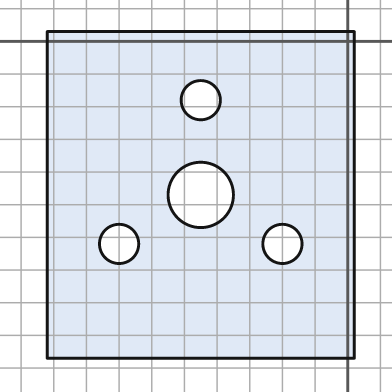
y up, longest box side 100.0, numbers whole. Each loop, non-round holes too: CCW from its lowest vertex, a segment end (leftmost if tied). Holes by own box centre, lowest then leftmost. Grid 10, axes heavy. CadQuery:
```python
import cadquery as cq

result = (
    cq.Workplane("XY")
    .moveTo(-92.0, -97.0)
    .lineTo(2.0, -97.0)
    .lineTo(2.0, 3.0)
    .lineTo(-92.0, 3.0)
    .close()
    .moveTo(-70.0, -62.0)
    .circle(6.0)
    .moveTo(-20.0, -62.0)
    .circle(6.0)
    .moveTo(-45.0, -47.0)
    .circle(10.0)
    .moveTo(-45.0, -18.0)
    .circle(6.0)
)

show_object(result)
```